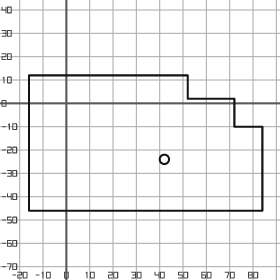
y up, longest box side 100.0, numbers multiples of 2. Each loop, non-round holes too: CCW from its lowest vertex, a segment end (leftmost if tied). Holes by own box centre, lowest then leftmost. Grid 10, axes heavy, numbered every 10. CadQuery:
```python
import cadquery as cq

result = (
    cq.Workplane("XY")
    .moveTo(-16.0, -46.0)
    .lineTo(84.0, -46.0)
    .lineTo(84.0, -10.0)
    .lineTo(72.0, -10.0)
    .lineTo(72.0, 2.0)
    .lineTo(52.0, 2.0)
    .lineTo(52.0, 12.0)
    .lineTo(-16.0, 12.0)
    .close()
    .moveTo(42.0, -24.0)
    .circle(2.0)
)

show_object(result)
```